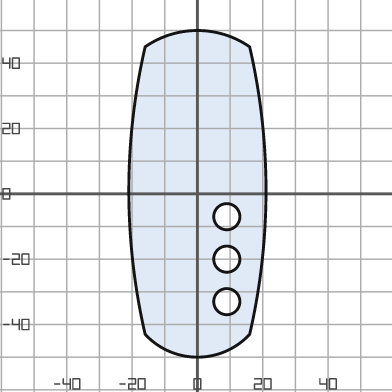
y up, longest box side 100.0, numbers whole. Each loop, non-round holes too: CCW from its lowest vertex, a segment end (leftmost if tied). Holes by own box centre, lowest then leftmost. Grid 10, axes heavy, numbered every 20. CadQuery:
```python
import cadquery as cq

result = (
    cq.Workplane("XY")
    .moveTo(-16.0, -43.0)
    .threePointArc((0.0, -50.0), (16.0, -43.0))
    .threePointArc((21.0, 1.0), (16.0, 45.0))
    .threePointArc((0.0, 50.0), (-16.0, 45.0))
    .threePointArc((-21.0, 1.0), (-16.0, -43.0))
    .close()
    .moveTo(9.0, -33.0)
    .circle(4.0)
    .moveTo(9.0, -20.0)
    .circle(4.0)
    .moveTo(9.0, -7.0)
    .circle(4.0)
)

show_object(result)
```